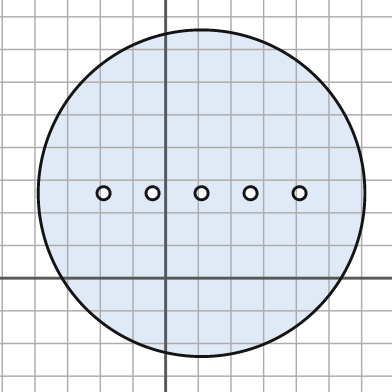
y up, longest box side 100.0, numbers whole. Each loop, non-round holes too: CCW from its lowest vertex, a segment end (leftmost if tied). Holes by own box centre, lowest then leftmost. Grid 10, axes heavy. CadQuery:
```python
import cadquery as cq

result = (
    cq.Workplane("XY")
    .moveTo(11.0, 26.0)
    .circle(50.0)
    .moveTo(-19.0, 26.0)
    .circle(2.0)
    .moveTo(-4.0, 26.0)
    .circle(2.0)
    .moveTo(11.0, 26.0)
    .circle(2.0)
    .moveTo(26.0, 26.0)
    .circle(2.0)
    .moveTo(41.0, 26.0)
    .circle(2.0)
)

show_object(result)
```